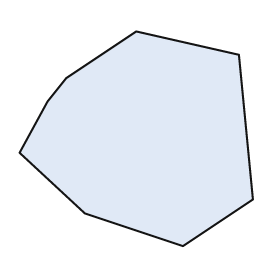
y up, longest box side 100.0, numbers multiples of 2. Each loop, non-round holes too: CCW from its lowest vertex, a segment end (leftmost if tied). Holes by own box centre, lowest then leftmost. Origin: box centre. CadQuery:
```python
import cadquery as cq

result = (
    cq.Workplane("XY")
    .moveTo(20.0, -46.0)
    .lineTo(50.0, -26.0)
    .lineTo(44.0, 36.0)
    .lineTo(0.0, 46.0)
    .lineTo(-30.0, 26.0)
    .lineTo(-38.0, 16.0)
    .lineTo(-50.0, -6.0)
    .lineTo(-22.0, -32.0)
    .close()
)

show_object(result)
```